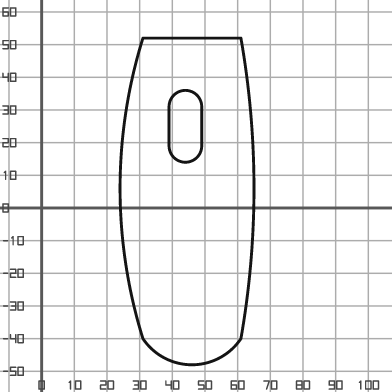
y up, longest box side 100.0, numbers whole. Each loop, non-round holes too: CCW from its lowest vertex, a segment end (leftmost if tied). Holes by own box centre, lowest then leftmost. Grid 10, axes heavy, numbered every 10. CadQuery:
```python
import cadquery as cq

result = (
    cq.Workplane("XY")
    .moveTo(31.0, -40.0)
    .threePointArc((46.0, -48.0), (61.0, -40.0))
    .threePointArc((65.0, 6.0), (61.0, 52.0))
    .lineTo(31.0, 52.0)
    .threePointArc((24.0, 6.0), (31.0, -40.0))
    .close()
    .moveTo(39.0, 19.0)
    .threePointArc((44.0, 14.0), (49.0, 19.0))
    .lineTo(49.0, 31.0)
    .threePointArc((44.0, 36.0), (39.0, 31.0))
    .close()
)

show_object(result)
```